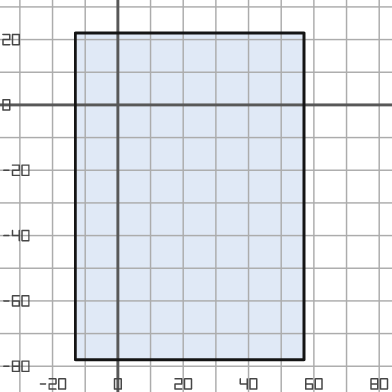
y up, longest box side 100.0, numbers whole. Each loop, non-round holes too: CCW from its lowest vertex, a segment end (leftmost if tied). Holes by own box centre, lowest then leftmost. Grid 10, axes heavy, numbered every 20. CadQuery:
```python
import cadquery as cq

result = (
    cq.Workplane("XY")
    .moveTo(-13.0, -78.0)
    .lineTo(57.0, -78.0)
    .lineTo(57.0, 22.0)
    .lineTo(-13.0, 22.0)
    .close()
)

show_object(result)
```